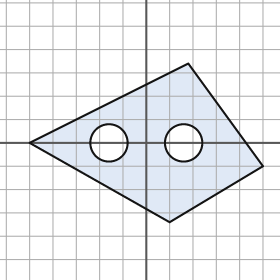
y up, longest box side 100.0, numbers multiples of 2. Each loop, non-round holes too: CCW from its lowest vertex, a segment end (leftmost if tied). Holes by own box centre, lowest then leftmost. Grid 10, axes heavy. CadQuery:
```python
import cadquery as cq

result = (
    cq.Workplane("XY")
    .moveTo(10.0, -34.0)
    .lineTo(50.0, -10.0)
    .lineTo(18.0, 34.0)
    .lineTo(-50.0, 0.0)
    .close()
    .moveTo(-16.0, 0.0)
    .circle(8.0)
    .moveTo(16.0, 0.0)
    .circle(8.0)
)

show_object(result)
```